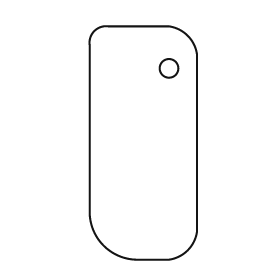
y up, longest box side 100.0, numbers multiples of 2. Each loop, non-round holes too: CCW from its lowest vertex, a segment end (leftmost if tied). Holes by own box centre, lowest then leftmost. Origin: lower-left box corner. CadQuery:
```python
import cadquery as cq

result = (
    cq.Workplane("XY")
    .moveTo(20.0, 0.0)
    .lineTo(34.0, 0.0)
    .threePointArc((42.0, 4.0), (46.0, 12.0))
    .lineTo(46.0, 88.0)
    .threePointArc((42.0, 96.0), (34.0, 100.0))
    .lineTo(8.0, 100.0)
    .threePointArc((2.0, 98.0), (0.0, 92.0))
    .lineTo(0.0, 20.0)
    .threePointArc((6.0, 6.0), (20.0, 0.0))
    .close()
    .moveTo(34.0, 82.0)
    .circle(4.0)
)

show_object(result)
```